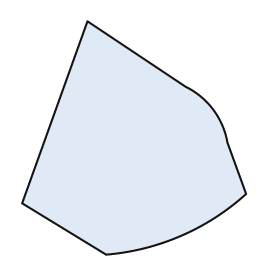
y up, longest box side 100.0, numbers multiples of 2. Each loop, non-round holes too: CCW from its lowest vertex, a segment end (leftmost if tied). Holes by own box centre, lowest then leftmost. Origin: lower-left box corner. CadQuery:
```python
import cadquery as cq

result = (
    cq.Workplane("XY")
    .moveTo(36.0, 0.0)
    .threePointArc((68.0, 8.0), (96.0, 26.0))
    .lineTo(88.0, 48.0)
    .threePointArc((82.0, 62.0), (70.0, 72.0))
    .lineTo(28.0, 100.0)
    .lineTo(0.0, 22.0)
    .close()
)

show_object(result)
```